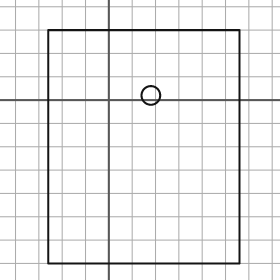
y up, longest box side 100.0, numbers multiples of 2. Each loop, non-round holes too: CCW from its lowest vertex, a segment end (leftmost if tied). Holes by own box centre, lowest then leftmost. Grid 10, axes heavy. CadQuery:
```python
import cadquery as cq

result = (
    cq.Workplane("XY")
    .moveTo(-26.0, -70.0)
    .lineTo(56.0, -70.0)
    .lineTo(56.0, 30.0)
    .lineTo(-26.0, 30.0)
    .close()
    .moveTo(18.0, 2.0)
    .circle(4.0)
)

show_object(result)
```